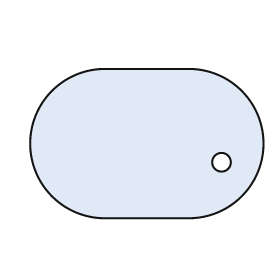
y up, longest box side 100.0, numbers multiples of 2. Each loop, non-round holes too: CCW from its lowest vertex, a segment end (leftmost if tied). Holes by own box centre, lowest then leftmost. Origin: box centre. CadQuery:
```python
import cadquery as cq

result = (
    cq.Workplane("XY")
    .moveTo(-18.0, -32.0)
    .lineTo(18.0, -32.0)
    .threePointArc((50.0, 0.0), (18.0, 32.0))
    .lineTo(-18.0, 32.0)
    .threePointArc((-50.0, 0.0), (-18.0, -32.0))
    .close()
    .moveTo(32.0, -8.0)
    .circle(4.0)
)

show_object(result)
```